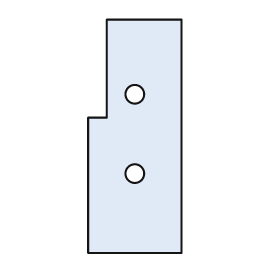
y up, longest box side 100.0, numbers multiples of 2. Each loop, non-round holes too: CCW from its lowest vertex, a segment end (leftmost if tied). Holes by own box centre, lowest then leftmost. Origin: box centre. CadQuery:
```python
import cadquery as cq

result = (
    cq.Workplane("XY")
    .moveTo(-20.0, -50.0)
    .lineTo(20.0, -50.0)
    .lineTo(20.0, 50.0)
    .lineTo(-12.0, 50.0)
    .lineTo(-12.0, 8.0)
    .lineTo(-20.0, 8.0)
    .close()
    .moveTo(0.0, -16.0)
    .circle(4.0)
    .moveTo(0.0, 18.0)
    .circle(4.0)
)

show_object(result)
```